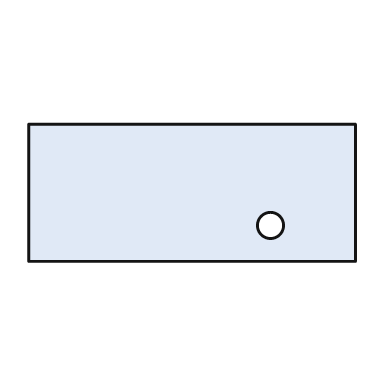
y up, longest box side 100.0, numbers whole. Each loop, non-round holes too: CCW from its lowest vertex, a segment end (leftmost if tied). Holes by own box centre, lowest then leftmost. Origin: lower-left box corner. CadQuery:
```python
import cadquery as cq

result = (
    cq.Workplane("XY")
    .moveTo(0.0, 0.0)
    .lineTo(100.0, 0.0)
    .lineTo(100.0, 42.0)
    .lineTo(0.0, 42.0)
    .close()
    .moveTo(74.0, 11.0)
    .circle(4.0)
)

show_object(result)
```